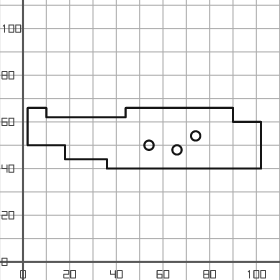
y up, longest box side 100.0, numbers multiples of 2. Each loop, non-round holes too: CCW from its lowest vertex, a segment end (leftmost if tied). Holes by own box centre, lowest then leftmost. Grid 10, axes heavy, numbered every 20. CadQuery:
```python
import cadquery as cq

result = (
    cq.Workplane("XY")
    .moveTo(36.0, 40.0)
    .lineTo(102.0, 40.0)
    .lineTo(102.0, 60.0)
    .lineTo(90.0, 60.0)
    .lineTo(90.0, 66.0)
    .lineTo(44.0, 66.0)
    .lineTo(44.0, 62.0)
    .lineTo(10.0, 62.0)
    .lineTo(10.0, 66.0)
    .lineTo(2.0, 66.0)
    .lineTo(2.0, 50.0)
    .lineTo(18.0, 50.0)
    .lineTo(18.0, 44.0)
    .lineTo(36.0, 44.0)
    .close()
    .moveTo(66.0, 48.0)
    .circle(2.0)
    .moveTo(54.0, 50.0)
    .circle(2.0)
    .moveTo(74.0, 54.0)
    .circle(2.0)
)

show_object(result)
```